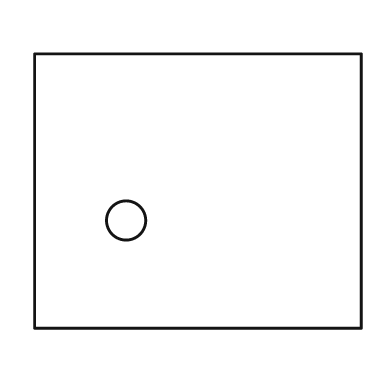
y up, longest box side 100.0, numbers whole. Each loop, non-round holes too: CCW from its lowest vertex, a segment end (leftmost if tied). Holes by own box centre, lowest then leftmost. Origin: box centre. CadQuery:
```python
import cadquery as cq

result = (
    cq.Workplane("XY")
    .moveTo(-50.0, -42.0)
    .lineTo(50.0, -42.0)
    .lineTo(50.0, 42.0)
    .lineTo(-50.0, 42.0)
    .close()
    .moveTo(-22.0, -9.0)
    .circle(6.0)
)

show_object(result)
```